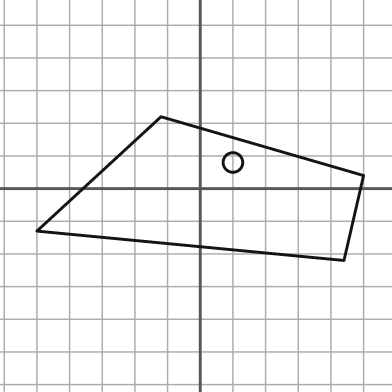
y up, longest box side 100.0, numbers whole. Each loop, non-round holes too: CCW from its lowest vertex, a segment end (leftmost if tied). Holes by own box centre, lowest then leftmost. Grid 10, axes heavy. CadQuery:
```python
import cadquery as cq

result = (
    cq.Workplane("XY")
    .moveTo(44.0, -22.0)
    .lineTo(50.0, 4.0)
    .lineTo(-12.0, 22.0)
    .lineTo(-50.0, -13.0)
    .close()
    .moveTo(10.0, 8.0)
    .circle(3.0)
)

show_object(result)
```